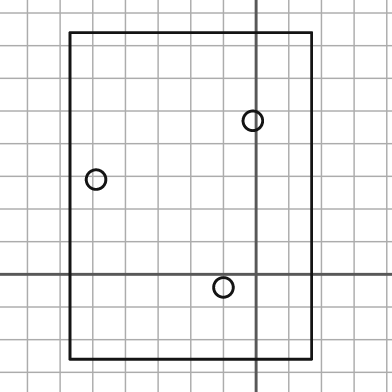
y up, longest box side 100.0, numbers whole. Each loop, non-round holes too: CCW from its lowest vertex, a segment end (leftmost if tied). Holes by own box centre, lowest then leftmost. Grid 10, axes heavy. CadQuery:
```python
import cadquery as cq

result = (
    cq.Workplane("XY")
    .moveTo(-57.0, -26.0)
    .lineTo(17.0, -26.0)
    .lineTo(17.0, 74.0)
    .lineTo(-57.0, 74.0)
    .close()
    .moveTo(-10.0, -4.0)
    .circle(3.0)
    .moveTo(-49.0, 29.0)
    .circle(3.0)
    .moveTo(-1.0, 47.0)
    .circle(3.0)
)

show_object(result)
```